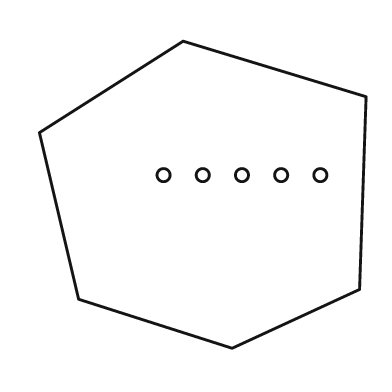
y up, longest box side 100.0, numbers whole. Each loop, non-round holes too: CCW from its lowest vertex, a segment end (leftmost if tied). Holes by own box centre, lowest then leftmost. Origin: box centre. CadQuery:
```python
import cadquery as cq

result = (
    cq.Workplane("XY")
    .moveTo(9.0, -47.0)
    .lineTo(48.0, -29.0)
    .lineTo(50.0, 30.0)
    .lineTo(-6.0, 47.0)
    .lineTo(-50.0, 19.0)
    .lineTo(-38.0, -32.0)
    .close()
    .moveTo(-12.0, 6.0)
    .circle(2.0)
    .moveTo(0.0, 6.0)
    .circle(2.0)
    .moveTo(12.0, 6.0)
    .circle(2.0)
    .moveTo(24.0, 6.0)
    .circle(2.0)
    .moveTo(36.0, 6.0)
    .circle(2.0)
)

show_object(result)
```